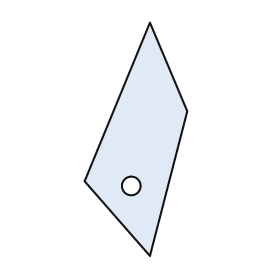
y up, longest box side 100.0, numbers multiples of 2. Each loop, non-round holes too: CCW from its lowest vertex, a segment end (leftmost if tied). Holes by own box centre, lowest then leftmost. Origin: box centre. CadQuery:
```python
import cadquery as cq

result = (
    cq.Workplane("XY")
    .moveTo(6.0, -50.0)
    .lineTo(22.0, 12.0)
    .lineTo(6.0, 50.0)
    .lineTo(-22.0, -18.0)
    .close()
    .moveTo(-2.0, -20.0)
    .circle(4.0)
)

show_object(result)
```